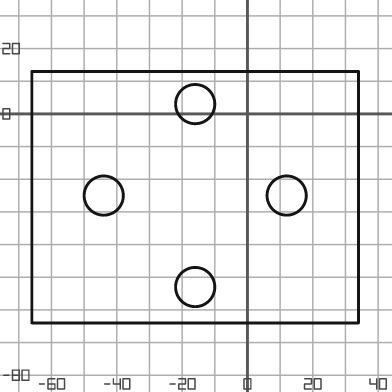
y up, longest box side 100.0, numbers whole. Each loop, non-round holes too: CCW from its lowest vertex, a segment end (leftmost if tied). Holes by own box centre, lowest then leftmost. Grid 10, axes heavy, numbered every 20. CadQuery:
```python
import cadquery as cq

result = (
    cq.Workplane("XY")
    .moveTo(-66.0, -64.0)
    .lineTo(34.0, -64.0)
    .lineTo(34.0, 13.0)
    .lineTo(-66.0, 13.0)
    .close()
    .moveTo(-16.0, -53.0)
    .circle(6.0)
    .moveTo(-44.0, -25.0)
    .circle(6.0)
    .moveTo(12.0, -25.0)
    .circle(6.0)
    .moveTo(-16.0, 3.0)
    .circle(6.0)
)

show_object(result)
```